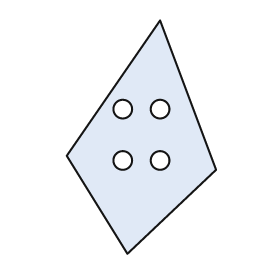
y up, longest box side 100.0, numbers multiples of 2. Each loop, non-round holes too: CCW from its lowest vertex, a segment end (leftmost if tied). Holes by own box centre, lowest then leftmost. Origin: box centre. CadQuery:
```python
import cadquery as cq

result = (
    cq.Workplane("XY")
    .moveTo(-6.0, -50.0)
    .lineTo(32.0, -14.0)
    .lineTo(8.0, 50.0)
    .lineTo(-32.0, -8.0)
    .close()
    .moveTo(-8.0, -10.0)
    .circle(4.0)
    .moveTo(8.0, -10.0)
    .circle(4.0)
    .moveTo(-8.0, 12.0)
    .circle(4.0)
    .moveTo(8.0, 12.0)
    .circle(4.0)
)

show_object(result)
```